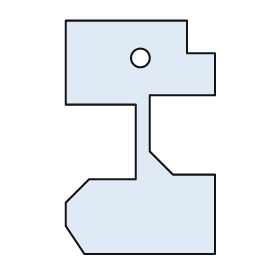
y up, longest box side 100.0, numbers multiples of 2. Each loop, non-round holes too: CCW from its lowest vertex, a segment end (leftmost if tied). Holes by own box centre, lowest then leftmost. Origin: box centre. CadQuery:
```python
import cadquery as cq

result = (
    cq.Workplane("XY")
    .moveTo(-24.0, -50.0)
    .lineTo(32.0, -50.0)
    .lineTo(32.0, -16.0)
    .lineTo(14.0, -16.0)
    .lineTo(4.0, -6.0)
    .lineTo(4.0, 18.0)
    .lineTo(32.0, 18.0)
    .lineTo(32.0, 36.0)
    .lineTo(20.0, 36.0)
    .lineTo(20.0, 50.0)
    .lineTo(-32.0, 50.0)
    .lineTo(-32.0, 14.0)
    .lineTo(-2.0, 14.0)
    .lineTo(-2.0, -18.0)
    .lineTo(-22.0, -18.0)
    .lineTo(-32.0, -28.0)
    .lineTo(-32.0, -38.0)
    .close()
    .moveTo(0.0, 34.0)
    .circle(4.0)
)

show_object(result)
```